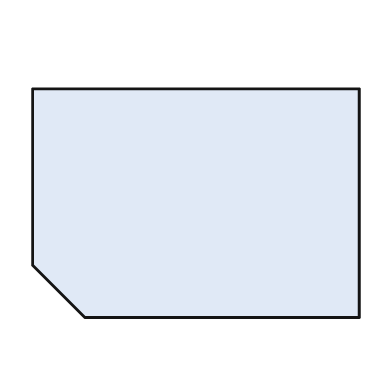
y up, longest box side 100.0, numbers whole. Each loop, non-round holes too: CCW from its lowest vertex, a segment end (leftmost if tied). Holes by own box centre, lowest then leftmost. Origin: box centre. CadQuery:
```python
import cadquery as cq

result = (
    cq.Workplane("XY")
    .moveTo(-34.0, -35.0)
    .lineTo(50.0, -35.0)
    .lineTo(50.0, 35.0)
    .lineTo(-50.0, 35.0)
    .lineTo(-50.0, -19.0)
    .close()
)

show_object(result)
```